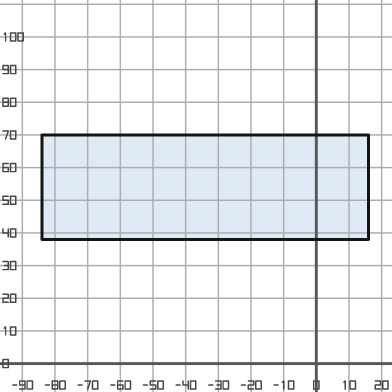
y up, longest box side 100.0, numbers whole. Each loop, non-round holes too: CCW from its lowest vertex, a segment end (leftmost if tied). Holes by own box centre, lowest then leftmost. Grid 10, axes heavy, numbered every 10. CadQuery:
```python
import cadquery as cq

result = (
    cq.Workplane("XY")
    .moveTo(-84.0, 38.0)
    .lineTo(16.0, 38.0)
    .lineTo(16.0, 70.0)
    .lineTo(-84.0, 70.0)
    .close()
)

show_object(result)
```